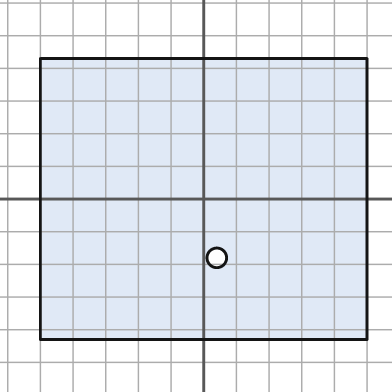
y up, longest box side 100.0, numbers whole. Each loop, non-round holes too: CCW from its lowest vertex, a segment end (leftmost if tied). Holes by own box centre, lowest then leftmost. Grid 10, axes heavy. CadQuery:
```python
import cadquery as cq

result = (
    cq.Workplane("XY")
    .moveTo(-50.0, -43.0)
    .lineTo(50.0, -43.0)
    .lineTo(50.0, 43.0)
    .lineTo(-50.0, 43.0)
    .close()
    .moveTo(4.0, -18.0)
    .circle(3.0)
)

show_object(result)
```